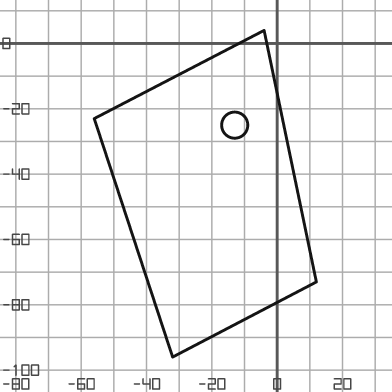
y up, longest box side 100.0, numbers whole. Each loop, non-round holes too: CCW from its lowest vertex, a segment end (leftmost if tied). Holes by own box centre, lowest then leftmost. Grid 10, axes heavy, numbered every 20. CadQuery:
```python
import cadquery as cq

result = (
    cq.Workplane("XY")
    .moveTo(-32.0, -96.0)
    .lineTo(12.0, -73.0)
    .lineTo(-4.0, 4.0)
    .lineTo(-56.0, -23.0)
    .close()
    .moveTo(-13.0, -25.0)
    .circle(4.0)
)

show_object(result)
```